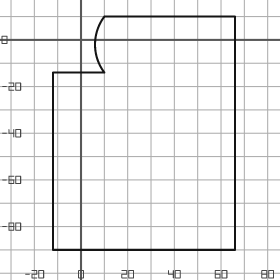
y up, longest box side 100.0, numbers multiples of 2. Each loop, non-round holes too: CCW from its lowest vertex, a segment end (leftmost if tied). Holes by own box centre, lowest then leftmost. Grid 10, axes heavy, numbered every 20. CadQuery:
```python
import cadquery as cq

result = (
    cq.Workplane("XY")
    .moveTo(-12.0, -90.0)
    .lineTo(66.0, -90.0)
    .lineTo(66.0, 10.0)
    .lineTo(10.0, 10.0)
    .threePointArc((6.0, -2.0), (10.0, -14.0))
    .lineTo(-12.0, -14.0)
    .close()
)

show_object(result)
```